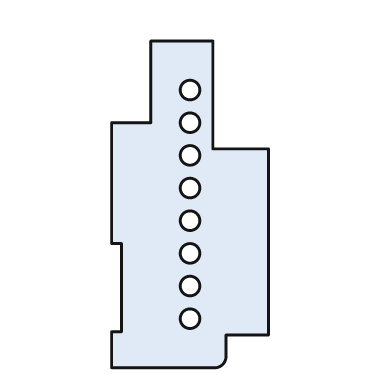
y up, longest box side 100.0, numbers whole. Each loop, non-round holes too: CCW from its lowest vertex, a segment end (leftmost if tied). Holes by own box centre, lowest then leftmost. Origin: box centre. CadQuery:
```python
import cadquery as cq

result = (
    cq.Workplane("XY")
    .moveTo(-24.0, -50.0)
    .lineTo(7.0, -50.0)
    .threePointArc((10.0, -49.0), (11.0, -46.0))
    .lineTo(11.0, -40.0)
    .lineTo(24.0, -40.0)
    .lineTo(24.0, 17.0)
    .lineTo(7.0, 17.0)
    .lineTo(7.0, 50.0)
    .lineTo(-12.0, 50.0)
    .lineTo(-12.0, 25.0)
    .lineTo(-24.0, 25.0)
    .lineTo(-24.0, -12.0)
    .lineTo(-21.0, -12.0)
    .lineTo(-21.0, -39.0)
    .lineTo(-24.0, -39.0)
    .close()
    .moveTo(0.0, -35.0)
    .circle(3.0)
    .moveTo(0.0, -25.0)
    .circle(3.0)
    .moveTo(0.0, -15.0)
    .circle(3.0)
    .moveTo(0.0, -5.0)
    .circle(3.0)
    .moveTo(0.0, 5.0)
    .circle(3.0)
    .moveTo(0.0, 15.0)
    .circle(3.0)
    .moveTo(0.0, 25.0)
    .circle(3.0)
    .moveTo(0.0, 35.0)
    .circle(3.0)
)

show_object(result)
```